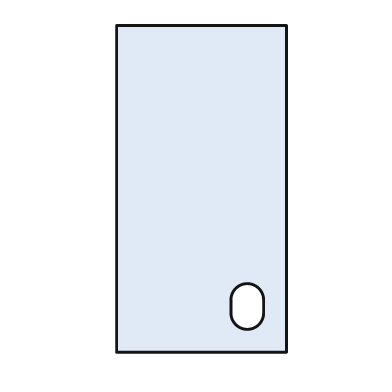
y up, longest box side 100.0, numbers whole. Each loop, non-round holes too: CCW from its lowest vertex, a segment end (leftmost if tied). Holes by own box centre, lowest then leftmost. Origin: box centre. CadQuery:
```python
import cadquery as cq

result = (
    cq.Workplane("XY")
    .moveTo(-26.0, -50.0)
    .lineTo(26.0, -50.0)
    .lineTo(26.0, 50.0)
    .lineTo(-26.0, 50.0)
    .close()
    .moveTo(9.0, -38.0)
    .threePointArc((14.0, -43.0), (19.0, -38.0))
    .lineTo(19.0, -34.0)
    .threePointArc((14.0, -29.0), (9.0, -34.0))
    .close()
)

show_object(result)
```